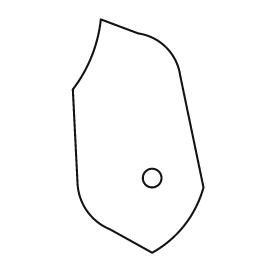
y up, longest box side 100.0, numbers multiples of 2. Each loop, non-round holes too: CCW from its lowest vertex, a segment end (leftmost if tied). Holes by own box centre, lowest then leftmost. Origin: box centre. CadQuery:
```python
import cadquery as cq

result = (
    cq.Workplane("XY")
    .moveTo(6.0, -50.0)
    .threePointArc((20.0, -38.0), (28.0, -22.0))
    .lineTo(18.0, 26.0)
    .threePointArc((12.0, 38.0), (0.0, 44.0))
    .lineTo(-16.0, 50.0)
    .threePointArc((-20.0, 34.0), (-28.0, 20.0))
    .lineTo(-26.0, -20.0)
    .threePointArc((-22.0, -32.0), (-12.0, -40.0))
    .close()
    .moveTo(6.0, -18.0)
    .circle(4.0)
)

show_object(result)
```